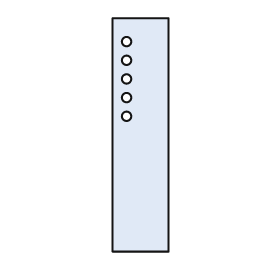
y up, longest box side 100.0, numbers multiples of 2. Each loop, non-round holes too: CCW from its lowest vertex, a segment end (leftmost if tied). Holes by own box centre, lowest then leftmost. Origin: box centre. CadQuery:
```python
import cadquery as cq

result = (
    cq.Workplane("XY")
    .moveTo(-12.0, -50.0)
    .lineTo(12.0, -50.0)
    .lineTo(12.0, 50.0)
    .lineTo(-12.0, 50.0)
    .close()
    .moveTo(-6.0, 8.0)
    .circle(2.0)
    .moveTo(-6.0, 16.0)
    .circle(2.0)
    .moveTo(-6.0, 24.0)
    .circle(2.0)
    .moveTo(-6.0, 32.0)
    .circle(2.0)
    .moveTo(-6.0, 40.0)
    .circle(2.0)
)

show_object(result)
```